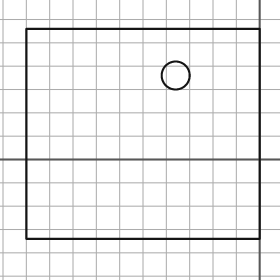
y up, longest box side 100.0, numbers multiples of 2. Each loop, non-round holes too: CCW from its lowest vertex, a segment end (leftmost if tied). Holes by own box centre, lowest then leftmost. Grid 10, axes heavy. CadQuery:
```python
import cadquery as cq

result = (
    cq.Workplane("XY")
    .moveTo(-100.0, -34.0)
    .lineTo(0.0, -34.0)
    .lineTo(0.0, 56.0)
    .lineTo(-100.0, 56.0)
    .close()
    .moveTo(-36.0, 36.0)
    .circle(6.0)
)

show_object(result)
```